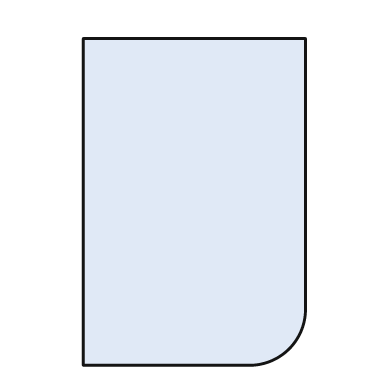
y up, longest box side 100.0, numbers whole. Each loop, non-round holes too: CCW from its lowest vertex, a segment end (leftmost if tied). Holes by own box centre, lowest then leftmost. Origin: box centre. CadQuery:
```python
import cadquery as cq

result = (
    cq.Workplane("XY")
    .moveTo(-34.0, -50.0)
    .lineTo(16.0, -50.0)
    .threePointArc((29.0, -45.0), (34.0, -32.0))
    .lineTo(34.0, 50.0)
    .lineTo(-34.0, 50.0)
    .close()
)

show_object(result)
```